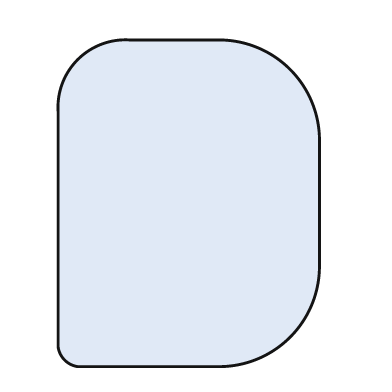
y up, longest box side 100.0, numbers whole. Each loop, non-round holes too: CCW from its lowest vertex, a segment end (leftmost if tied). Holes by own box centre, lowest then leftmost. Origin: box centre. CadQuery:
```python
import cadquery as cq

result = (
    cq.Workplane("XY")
    .moveTo(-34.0, -50.0)
    .lineTo(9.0, -50.0)
    .threePointArc((31.0, -41.0), (40.0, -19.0))
    .lineTo(40.0, 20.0)
    .threePointArc((31.0, 41.0), (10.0, 50.0))
    .lineTo(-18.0, 50.0)
    .threePointArc((-34.0, 44.0), (-40.0, 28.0))
    .lineTo(-40.0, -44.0)
    .threePointArc((-38.0, -48.0), (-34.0, -50.0))
    .close()
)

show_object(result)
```